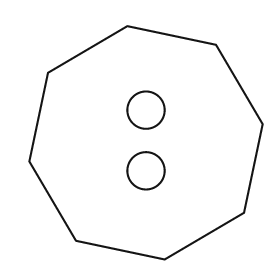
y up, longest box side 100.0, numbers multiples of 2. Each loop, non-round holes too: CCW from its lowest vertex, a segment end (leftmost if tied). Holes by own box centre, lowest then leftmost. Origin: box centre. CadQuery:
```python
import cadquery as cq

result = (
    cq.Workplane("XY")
    .moveTo(8.0, -50.0)
    .lineTo(42.0, -30.0)
    .lineTo(50.0, 8.0)
    .lineTo(30.0, 42.0)
    .lineTo(-8.0, 50.0)
    .lineTo(-42.0, 30.0)
    .lineTo(-50.0, -8.0)
    .lineTo(-30.0, -42.0)
    .close()
    .moveTo(0.0, -12.0)
    .circle(8.0)
    .moveTo(0.0, 14.0)
    .circle(8.0)
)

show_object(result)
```